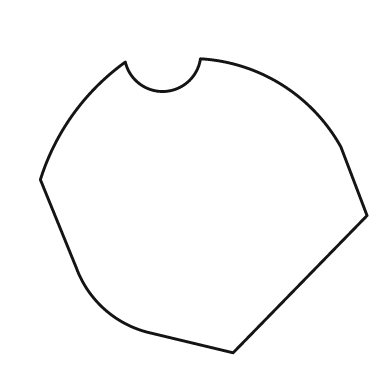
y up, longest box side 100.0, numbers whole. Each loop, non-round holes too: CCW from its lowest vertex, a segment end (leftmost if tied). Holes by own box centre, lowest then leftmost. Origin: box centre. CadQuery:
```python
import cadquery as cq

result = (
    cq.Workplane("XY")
    .moveTo(9.0, -45.0)
    .lineTo(50.0, -3.0)
    .lineTo(42.0, 18.0)
    .threePointArc((24.0, 37.0), (-1.0, 45.0))
    .threePointArc((-12.0, 35.0), (-24.0, 44.0))
    .threePointArc((-40.0, 28.0), (-50.0, 8.0))
    .lineTo(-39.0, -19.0)
    .threePointArc((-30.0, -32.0), (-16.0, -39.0))
    .close()
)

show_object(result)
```